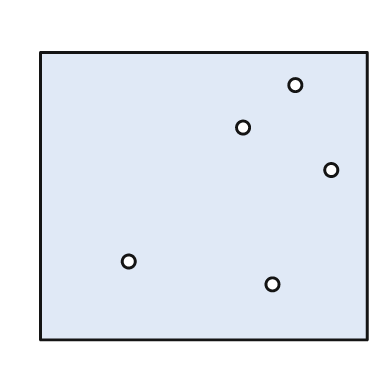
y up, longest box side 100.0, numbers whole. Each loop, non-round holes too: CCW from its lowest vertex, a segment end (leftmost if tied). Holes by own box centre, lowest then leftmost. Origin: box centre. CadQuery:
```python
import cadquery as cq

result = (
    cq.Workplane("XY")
    .moveTo(-50.0, -44.0)
    .lineTo(50.0, -44.0)
    .lineTo(50.0, 44.0)
    .lineTo(-50.0, 44.0)
    .close()
    .moveTo(21.0, -27.0)
    .circle(2.0)
    .moveTo(-23.0, -20.0)
    .circle(2.0)
    .moveTo(39.0, 8.0)
    .circle(2.0)
    .moveTo(12.0, 21.0)
    .circle(2.0)
    .moveTo(28.0, 34.0)
    .circle(2.0)
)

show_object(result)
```